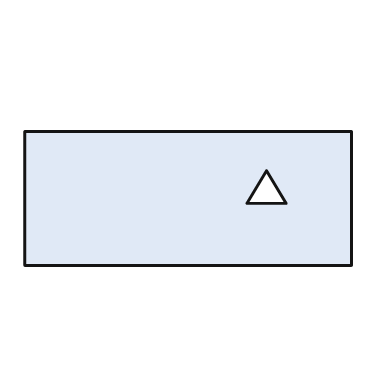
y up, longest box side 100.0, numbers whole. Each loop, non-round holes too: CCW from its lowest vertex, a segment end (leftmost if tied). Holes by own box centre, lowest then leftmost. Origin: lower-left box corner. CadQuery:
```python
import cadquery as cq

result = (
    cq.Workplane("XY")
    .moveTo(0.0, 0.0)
    .lineTo(100.0, 0.0)
    .lineTo(100.0, 41.0)
    .lineTo(0.0, 41.0)
    .close()
    .moveTo(68.0, 19.0)
    .lineTo(80.0, 19.0)
    .lineTo(74.0, 29.0)
    .close()
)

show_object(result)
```